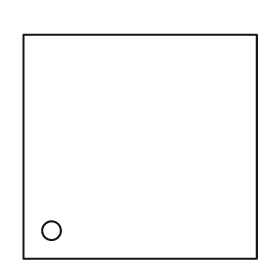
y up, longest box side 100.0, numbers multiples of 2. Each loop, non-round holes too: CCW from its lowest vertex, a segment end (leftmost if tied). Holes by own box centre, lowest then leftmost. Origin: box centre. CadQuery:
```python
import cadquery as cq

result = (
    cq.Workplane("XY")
    .moveTo(-50.0, -48.0)
    .lineTo(50.0, -48.0)
    .lineTo(50.0, 48.0)
    .lineTo(-50.0, 48.0)
    .close()
    .moveTo(-38.0, -36.0)
    .circle(4.0)
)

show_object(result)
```